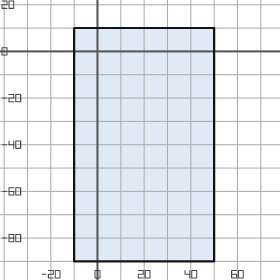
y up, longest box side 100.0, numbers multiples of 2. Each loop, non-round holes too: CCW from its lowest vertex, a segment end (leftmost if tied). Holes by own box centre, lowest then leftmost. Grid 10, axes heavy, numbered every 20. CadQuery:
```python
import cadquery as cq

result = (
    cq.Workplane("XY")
    .moveTo(-10.0, -90.0)
    .lineTo(50.0, -90.0)
    .lineTo(50.0, 10.0)
    .lineTo(-10.0, 10.0)
    .close()
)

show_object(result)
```